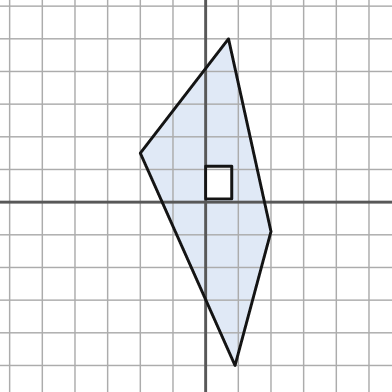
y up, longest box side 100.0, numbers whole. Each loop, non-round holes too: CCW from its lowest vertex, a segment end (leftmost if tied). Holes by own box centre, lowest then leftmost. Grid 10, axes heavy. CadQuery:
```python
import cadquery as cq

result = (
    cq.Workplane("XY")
    .moveTo(9.0, -50.0)
    .lineTo(20.0, -9.0)
    .lineTo(7.0, 50.0)
    .lineTo(-20.0, 15.0)
    .close()
    .moveTo(0.0, 1.0)
    .lineTo(8.0, 1.0)
    .lineTo(8.0, 11.0)
    .lineTo(0.0, 11.0)
    .close()
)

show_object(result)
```